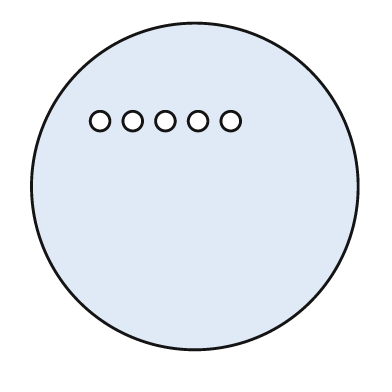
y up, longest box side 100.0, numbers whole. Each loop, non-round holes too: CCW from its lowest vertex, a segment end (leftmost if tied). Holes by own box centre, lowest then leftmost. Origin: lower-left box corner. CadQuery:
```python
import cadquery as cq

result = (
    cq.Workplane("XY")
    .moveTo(50.0, 50.0)
    .circle(50.0)
    .moveTo(21.0, 70.0)
    .circle(3.0)
    .moveTo(31.0, 70.0)
    .circle(3.0)
    .moveTo(41.0, 70.0)
    .circle(3.0)
    .moveTo(51.0, 70.0)
    .circle(3.0)
    .moveTo(61.0, 70.0)
    .circle(3.0)
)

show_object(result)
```